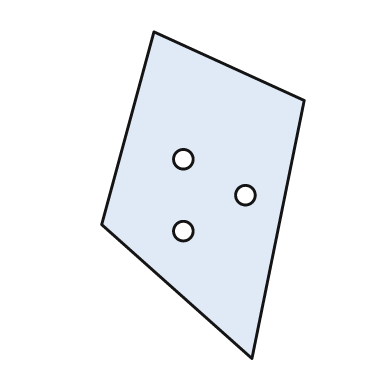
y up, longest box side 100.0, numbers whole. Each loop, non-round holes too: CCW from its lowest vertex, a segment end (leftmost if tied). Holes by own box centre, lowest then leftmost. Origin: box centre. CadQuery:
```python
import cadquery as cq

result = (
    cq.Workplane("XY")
    .moveTo(15.0, -50.0)
    .lineTo(31.0, 29.0)
    .lineTo(-15.0, 50.0)
    .lineTo(-31.0, -9.0)
    .close()
    .moveTo(-6.0, -11.0)
    .circle(3.0)
    .moveTo(13.0, 0.0)
    .circle(3.0)
    .moveTo(-6.0, 11.0)
    .circle(3.0)
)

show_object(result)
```